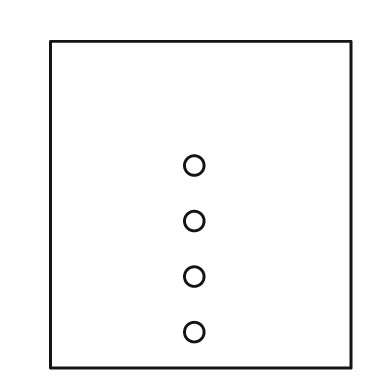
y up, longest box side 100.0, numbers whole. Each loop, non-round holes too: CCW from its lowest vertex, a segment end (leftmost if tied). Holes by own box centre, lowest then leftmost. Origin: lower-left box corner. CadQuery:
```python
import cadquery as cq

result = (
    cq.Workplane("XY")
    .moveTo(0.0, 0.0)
    .lineTo(92.0, 0.0)
    .lineTo(92.0, 100.0)
    .lineTo(0.0, 100.0)
    .close()
    .moveTo(44.0, 11.0)
    .circle(3.0)
    .moveTo(44.0, 28.0)
    .circle(3.0)
    .moveTo(44.0, 45.0)
    .circle(3.0)
    .moveTo(44.0, 62.0)
    .circle(3.0)
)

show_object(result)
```